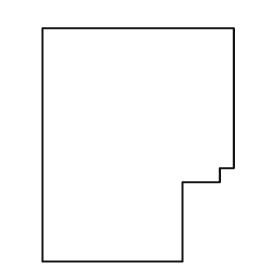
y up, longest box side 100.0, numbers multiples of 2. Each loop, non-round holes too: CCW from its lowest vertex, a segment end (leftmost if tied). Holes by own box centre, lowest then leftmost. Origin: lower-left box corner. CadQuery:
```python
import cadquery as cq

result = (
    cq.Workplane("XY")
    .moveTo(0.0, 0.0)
    .lineTo(60.0, 0.0)
    .lineTo(60.0, 34.0)
    .lineTo(76.0, 34.0)
    .lineTo(76.0, 40.0)
    .lineTo(82.0, 40.0)
    .lineTo(82.0, 100.0)
    .lineTo(0.0, 100.0)
    .close()
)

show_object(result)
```